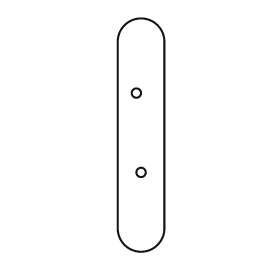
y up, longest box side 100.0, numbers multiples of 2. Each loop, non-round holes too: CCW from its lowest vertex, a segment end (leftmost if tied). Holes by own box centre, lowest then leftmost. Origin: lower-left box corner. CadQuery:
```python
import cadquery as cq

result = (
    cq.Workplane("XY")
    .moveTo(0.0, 10.0)
    .threePointArc((10.0, 0.0), (20.0, 10.0))
    .lineTo(20.0, 90.0)
    .threePointArc((10.0, 100.0), (0.0, 90.0))
    .close()
    .moveTo(10.0, 34.0)
    .circle(2.0)
    .moveTo(8.0, 68.0)
    .circle(2.0)
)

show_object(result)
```